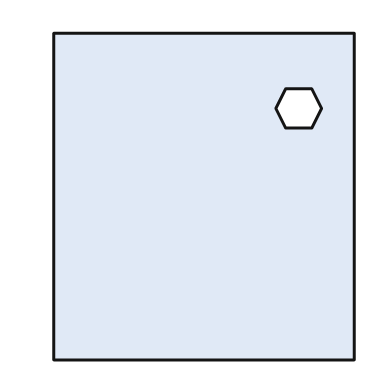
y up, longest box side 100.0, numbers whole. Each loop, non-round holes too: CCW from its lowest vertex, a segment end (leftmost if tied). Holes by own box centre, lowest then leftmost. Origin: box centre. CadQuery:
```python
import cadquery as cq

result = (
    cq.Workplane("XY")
    .moveTo(-46.0, -50.0)
    .lineTo(46.0, -50.0)
    .lineTo(46.0, 50.0)
    .lineTo(-46.0, 50.0)
    .close()
    .moveTo(25.0, 21.0)
    .lineTo(33.0, 21.0)
    .lineTo(36.0, 27.0)
    .lineTo(33.0, 33.0)
    .lineTo(25.0, 33.0)
    .lineTo(22.0, 27.0)
    .close()
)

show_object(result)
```